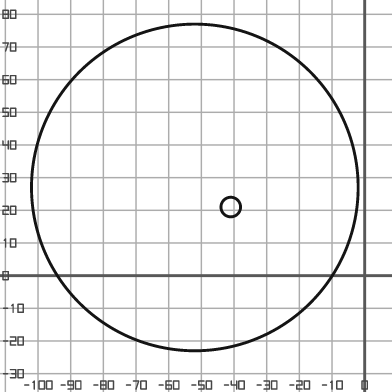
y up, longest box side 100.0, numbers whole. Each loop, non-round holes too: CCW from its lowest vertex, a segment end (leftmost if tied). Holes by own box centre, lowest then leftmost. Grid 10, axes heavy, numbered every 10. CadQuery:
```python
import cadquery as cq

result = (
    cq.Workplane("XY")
    .moveTo(-52.0, 27.0)
    .circle(50.0)
    .moveTo(-41.0, 21.0)
    .circle(3.0)
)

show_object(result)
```